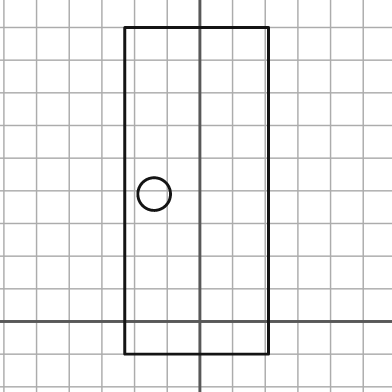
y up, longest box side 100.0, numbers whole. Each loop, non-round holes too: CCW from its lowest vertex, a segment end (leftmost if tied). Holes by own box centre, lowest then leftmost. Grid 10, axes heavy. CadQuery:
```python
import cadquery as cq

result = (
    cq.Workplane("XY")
    .moveTo(-23.0, -10.0)
    .lineTo(21.0, -10.0)
    .lineTo(21.0, 90.0)
    .lineTo(-23.0, 90.0)
    .close()
    .moveTo(-14.0, 39.0)
    .circle(5.0)
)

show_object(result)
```